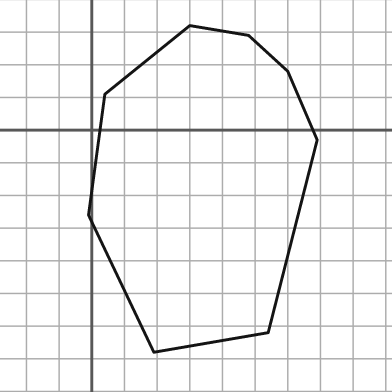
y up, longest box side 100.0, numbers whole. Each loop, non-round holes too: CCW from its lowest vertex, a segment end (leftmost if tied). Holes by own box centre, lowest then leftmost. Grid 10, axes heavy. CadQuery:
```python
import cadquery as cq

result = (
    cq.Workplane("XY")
    .moveTo(19.0, -68.0)
    .lineTo(54.0, -62.0)
    .lineTo(69.0, -3.0)
    .lineTo(60.0, 18.0)
    .lineTo(48.0, 29.0)
    .lineTo(30.0, 32.0)
    .lineTo(4.0, 11.0)
    .lineTo(-1.0, -26.0)
    .close()
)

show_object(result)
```